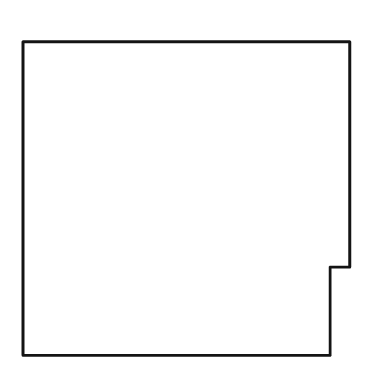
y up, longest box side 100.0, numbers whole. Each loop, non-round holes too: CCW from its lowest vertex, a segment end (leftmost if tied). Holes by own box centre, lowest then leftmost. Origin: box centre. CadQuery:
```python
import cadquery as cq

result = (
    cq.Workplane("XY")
    .moveTo(-50.0, -48.0)
    .lineTo(44.0, -48.0)
    .lineTo(44.0, -21.0)
    .lineTo(50.0, -21.0)
    .lineTo(50.0, 48.0)
    .lineTo(-50.0, 48.0)
    .close()
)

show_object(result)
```